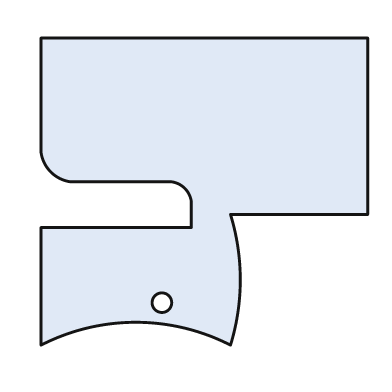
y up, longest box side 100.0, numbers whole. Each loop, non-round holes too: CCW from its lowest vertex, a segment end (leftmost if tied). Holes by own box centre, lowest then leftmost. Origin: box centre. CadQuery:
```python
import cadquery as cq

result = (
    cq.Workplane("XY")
    .moveTo(-50.0, -47.0)
    .threePointArc((-21.0, -40.0), (8.0, -47.0))
    .threePointArc((11.0, -27.0), (8.0, -7.0))
    .lineTo(50.0, -7.0)
    .lineTo(50.0, 47.0)
    .lineTo(-50.0, 47.0)
    .lineTo(-50.0, 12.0)
    .threePointArc((-47.0, 6.0), (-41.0, 3.0))
    .lineTo(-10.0, 3.0)
    .threePointArc((-6.0, 1.0), (-4.0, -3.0))
    .lineTo(-4.0, -11.0)
    .lineTo(-50.0, -11.0)
    .close()
    .moveTo(-13.0, -34.0)
    .circle(3.0)
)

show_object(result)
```